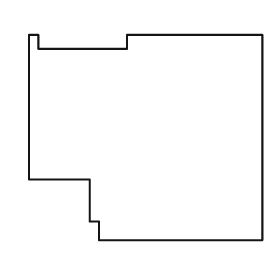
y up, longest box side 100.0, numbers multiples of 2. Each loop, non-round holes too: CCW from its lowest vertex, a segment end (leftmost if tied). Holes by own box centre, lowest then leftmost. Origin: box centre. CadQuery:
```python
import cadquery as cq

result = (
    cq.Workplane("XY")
    .moveTo(-20.0, -44.0)
    .lineTo(50.0, -44.0)
    .lineTo(50.0, 44.0)
    .lineTo(-8.0, 44.0)
    .lineTo(-8.0, 38.0)
    .lineTo(-46.0, 38.0)
    .lineTo(-46.0, 44.0)
    .lineTo(-50.0, 44.0)
    .lineTo(-50.0, -18.0)
    .lineTo(-24.0, -18.0)
    .lineTo(-24.0, -36.0)
    .lineTo(-20.0, -36.0)
    .close()
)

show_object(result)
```